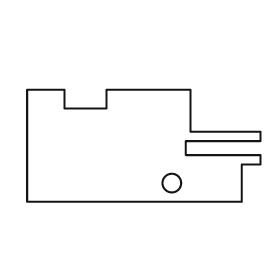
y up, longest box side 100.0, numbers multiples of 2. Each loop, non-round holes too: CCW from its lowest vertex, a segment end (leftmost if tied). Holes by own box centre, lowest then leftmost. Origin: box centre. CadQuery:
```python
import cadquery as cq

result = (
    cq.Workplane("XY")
    .moveTo(-50.0, -24.0)
    .lineTo(42.0, -24.0)
    .lineTo(42.0, -8.0)
    .lineTo(50.0, -8.0)
    .lineTo(50.0, -4.0)
    .lineTo(18.0, -4.0)
    .lineTo(18.0, 2.0)
    .lineTo(50.0, 2.0)
    .lineTo(50.0, 6.0)
    .lineTo(20.0, 6.0)
    .lineTo(20.0, 24.0)
    .lineTo(-16.0, 24.0)
    .lineTo(-16.0, 16.0)
    .lineTo(-34.0, 16.0)
    .lineTo(-34.0, 24.0)
    .lineTo(-50.0, 24.0)
    .close()
    .moveTo(12.0, -16.0)
    .circle(4.0)
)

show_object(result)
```